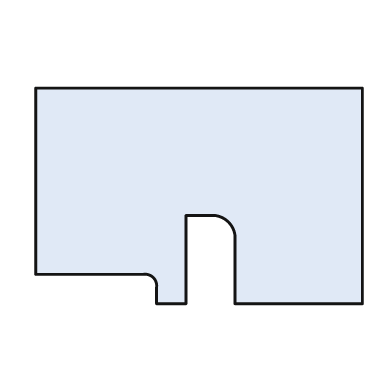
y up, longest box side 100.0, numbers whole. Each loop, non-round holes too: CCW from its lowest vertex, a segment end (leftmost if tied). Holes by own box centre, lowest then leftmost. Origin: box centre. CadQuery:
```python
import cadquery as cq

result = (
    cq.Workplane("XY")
    .moveTo(-13.0, -33.0)
    .lineTo(-4.0, -33.0)
    .lineTo(-4.0, -6.0)
    .lineTo(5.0, -6.0)
    .threePointArc((9.0, -8.0), (11.0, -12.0))
    .lineTo(11.0, -33.0)
    .lineTo(50.0, -33.0)
    .lineTo(50.0, 33.0)
    .lineTo(-50.0, 33.0)
    .lineTo(-50.0, -24.0)
    .lineTo(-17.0, -24.0)
    .threePointArc((-14.0, -25.0), (-13.0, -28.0))
    .close()
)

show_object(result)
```